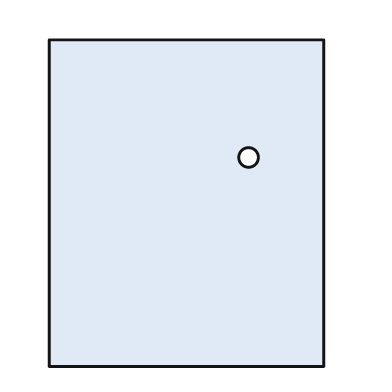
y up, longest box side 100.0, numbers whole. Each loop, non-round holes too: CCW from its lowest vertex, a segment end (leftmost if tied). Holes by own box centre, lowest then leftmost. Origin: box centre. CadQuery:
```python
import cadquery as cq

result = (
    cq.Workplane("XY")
    .moveTo(-42.0, -50.0)
    .lineTo(42.0, -50.0)
    .lineTo(42.0, 50.0)
    .lineTo(-42.0, 50.0)
    .close()
    .moveTo(19.0, 14.0)
    .circle(3.0)
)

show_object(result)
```